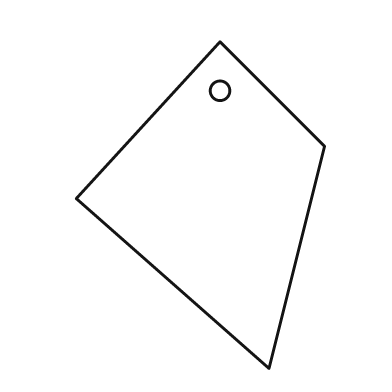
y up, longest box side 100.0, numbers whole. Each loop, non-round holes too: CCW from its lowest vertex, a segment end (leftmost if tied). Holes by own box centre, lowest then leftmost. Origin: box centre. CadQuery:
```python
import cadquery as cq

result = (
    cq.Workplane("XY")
    .moveTo(21.0, -50.0)
    .lineTo(38.0, 18.0)
    .lineTo(6.0, 50.0)
    .lineTo(-38.0, 2.0)
    .close()
    .moveTo(6.0, 35.0)
    .circle(3.0)
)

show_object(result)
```